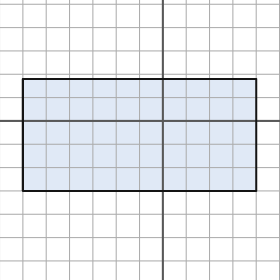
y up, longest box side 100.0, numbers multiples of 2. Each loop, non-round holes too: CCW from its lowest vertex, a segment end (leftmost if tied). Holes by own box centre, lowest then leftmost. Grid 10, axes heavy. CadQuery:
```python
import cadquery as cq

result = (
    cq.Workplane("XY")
    .moveTo(-60.0, -30.0)
    .lineTo(40.0, -30.0)
    .lineTo(40.0, 18.0)
    .lineTo(-60.0, 18.0)
    .close()
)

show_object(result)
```